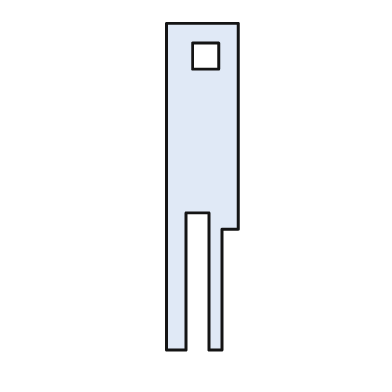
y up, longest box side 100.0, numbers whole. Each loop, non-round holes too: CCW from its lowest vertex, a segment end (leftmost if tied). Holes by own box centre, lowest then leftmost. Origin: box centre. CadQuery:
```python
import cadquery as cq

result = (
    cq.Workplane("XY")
    .moveTo(-11.0, -50.0)
    .lineTo(-5.0, -50.0)
    .lineTo(-5.0, -8.0)
    .lineTo(2.0, -8.0)
    .lineTo(2.0, -50.0)
    .lineTo(6.0, -50.0)
    .lineTo(6.0, -13.0)
    .lineTo(11.0, -13.0)
    .lineTo(11.0, 50.0)
    .lineTo(-11.0, 50.0)
    .close()
    .moveTo(-3.0, 36.0)
    .lineTo(5.0, 36.0)
    .lineTo(5.0, 44.0)
    .lineTo(-3.0, 44.0)
    .close()
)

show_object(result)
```